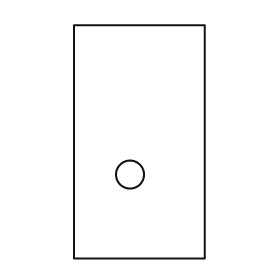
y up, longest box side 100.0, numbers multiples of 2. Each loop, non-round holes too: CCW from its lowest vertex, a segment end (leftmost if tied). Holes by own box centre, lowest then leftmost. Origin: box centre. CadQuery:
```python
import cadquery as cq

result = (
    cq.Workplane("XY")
    .moveTo(-28.0, -50.0)
    .lineTo(28.0, -50.0)
    .lineTo(28.0, 50.0)
    .lineTo(-28.0, 50.0)
    .close()
    .moveTo(-4.0, -14.0)
    .circle(6.0)
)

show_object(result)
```